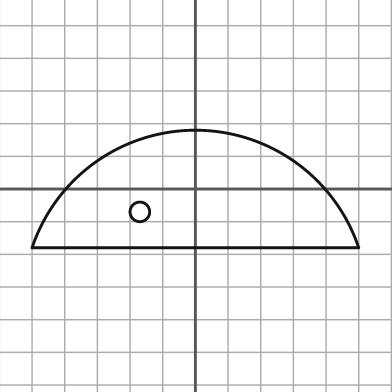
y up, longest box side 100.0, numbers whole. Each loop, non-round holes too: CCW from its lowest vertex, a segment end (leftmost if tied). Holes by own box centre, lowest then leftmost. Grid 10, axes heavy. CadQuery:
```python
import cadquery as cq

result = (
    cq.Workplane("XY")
    .moveTo(-50.0, -18.0)
    .lineTo(50.0, -18.0)
    .threePointArc((0.0, 18.0), (-50.0, -18.0))
    .close()
    .moveTo(-17.0, -7.0)
    .circle(3.0)
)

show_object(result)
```